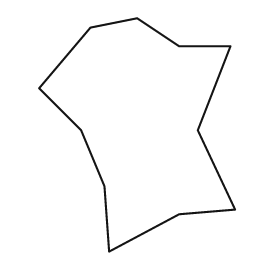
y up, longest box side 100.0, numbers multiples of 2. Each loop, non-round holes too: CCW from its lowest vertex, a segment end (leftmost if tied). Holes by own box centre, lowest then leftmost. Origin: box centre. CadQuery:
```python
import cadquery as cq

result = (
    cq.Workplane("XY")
    .moveTo(-12.0, -50.0)
    .lineTo(18.0, -34.0)
    .lineTo(42.0, -32.0)
    .lineTo(26.0, 2.0)
    .lineTo(40.0, 38.0)
    .lineTo(18.0, 38.0)
    .lineTo(0.0, 50.0)
    .lineTo(-20.0, 46.0)
    .lineTo(-42.0, 20.0)
    .lineTo(-24.0, 2.0)
    .lineTo(-14.0, -22.0)
    .close()
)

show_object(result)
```